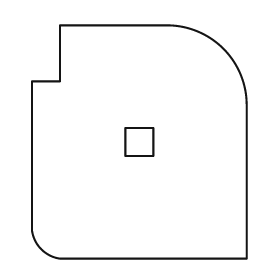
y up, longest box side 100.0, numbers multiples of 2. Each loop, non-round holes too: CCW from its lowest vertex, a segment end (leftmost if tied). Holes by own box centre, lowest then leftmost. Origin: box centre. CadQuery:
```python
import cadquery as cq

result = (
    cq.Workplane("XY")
    .moveTo(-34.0, -50.0)
    .lineTo(46.0, -50.0)
    .lineTo(46.0, 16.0)
    .threePointArc((36.0, 40.0), (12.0, 50.0))
    .lineTo(-34.0, 50.0)
    .lineTo(-34.0, 26.0)
    .lineTo(-46.0, 26.0)
    .lineTo(-46.0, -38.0)
    .threePointArc((-42.0, -46.0), (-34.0, -50.0))
    .close()
    .moveTo(-6.0, -6.0)
    .lineTo(6.0, -6.0)
    .lineTo(6.0, 6.0)
    .lineTo(-6.0, 6.0)
    .close()
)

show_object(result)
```